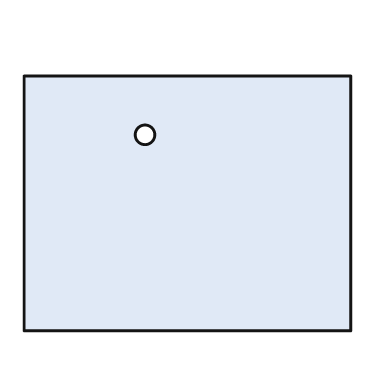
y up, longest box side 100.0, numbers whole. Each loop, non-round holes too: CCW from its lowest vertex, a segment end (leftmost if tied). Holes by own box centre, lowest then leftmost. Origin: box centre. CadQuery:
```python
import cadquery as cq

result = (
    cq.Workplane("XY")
    .moveTo(-50.0, -39.0)
    .lineTo(50.0, -39.0)
    .lineTo(50.0, 39.0)
    .lineTo(-50.0, 39.0)
    .close()
    .moveTo(-13.0, 21.0)
    .circle(3.0)
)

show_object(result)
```